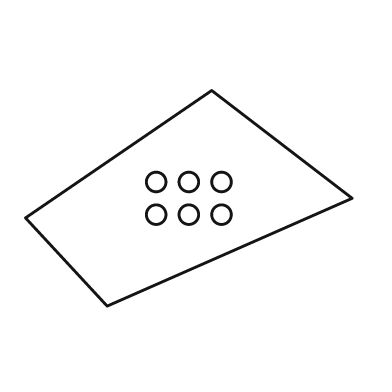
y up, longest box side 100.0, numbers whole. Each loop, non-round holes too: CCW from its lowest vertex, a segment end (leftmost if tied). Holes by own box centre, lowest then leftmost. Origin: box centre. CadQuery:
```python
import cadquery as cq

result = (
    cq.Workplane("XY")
    .moveTo(-25.0, -33.0)
    .lineTo(50.0, 0.0)
    .lineTo(7.0, 33.0)
    .lineTo(-50.0, -6.0)
    .close()
    .moveTo(-10.0, -5.0)
    .circle(3.0)
    .moveTo(0.0, -5.0)
    .circle(3.0)
    .moveTo(10.0, -5.0)
    .circle(3.0)
    .moveTo(-10.0, 5.0)
    .circle(3.0)
    .moveTo(0.0, 5.0)
    .circle(3.0)
    .moveTo(10.0, 5.0)
    .circle(3.0)
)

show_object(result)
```